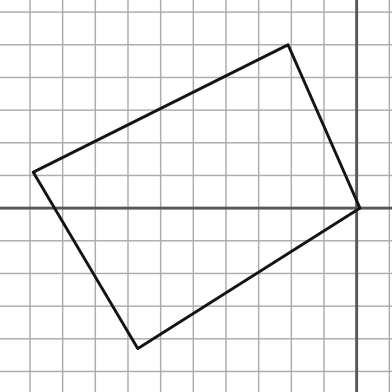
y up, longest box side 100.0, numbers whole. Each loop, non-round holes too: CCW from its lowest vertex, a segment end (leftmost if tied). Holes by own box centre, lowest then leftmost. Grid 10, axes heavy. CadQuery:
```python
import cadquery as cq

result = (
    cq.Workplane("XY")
    .moveTo(-67.0, -43.0)
    .lineTo(1.0, 0.0)
    .lineTo(-21.0, 50.0)
    .lineTo(-99.0, 11.0)
    .close()
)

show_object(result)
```